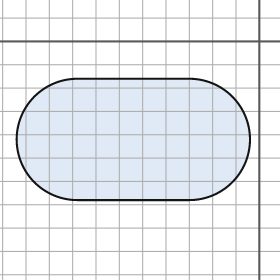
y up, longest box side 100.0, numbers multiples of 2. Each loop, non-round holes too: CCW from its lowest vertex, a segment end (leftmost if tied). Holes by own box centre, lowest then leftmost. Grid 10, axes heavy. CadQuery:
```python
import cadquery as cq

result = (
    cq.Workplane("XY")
    .moveTo(-78.0, -68.0)
    .lineTo(-30.0, -68.0)
    .threePointArc((-4.0, -42.0), (-30.0, -16.0))
    .lineTo(-78.0, -16.0)
    .threePointArc((-104.0, -42.0), (-78.0, -68.0))
    .close()
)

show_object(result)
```